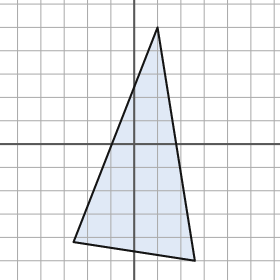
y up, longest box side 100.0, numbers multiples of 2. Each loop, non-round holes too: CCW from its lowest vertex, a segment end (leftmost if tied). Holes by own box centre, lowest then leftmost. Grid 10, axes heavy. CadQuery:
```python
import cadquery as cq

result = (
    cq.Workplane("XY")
    .moveTo(26.0, -50.0)
    .lineTo(10.0, 50.0)
    .lineTo(-26.0, -42.0)
    .close()
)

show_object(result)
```